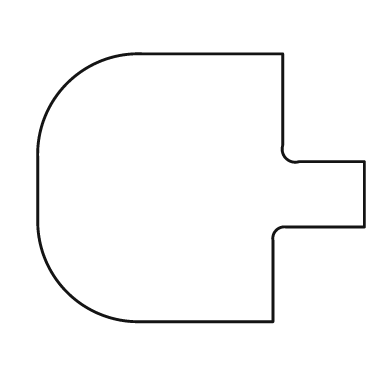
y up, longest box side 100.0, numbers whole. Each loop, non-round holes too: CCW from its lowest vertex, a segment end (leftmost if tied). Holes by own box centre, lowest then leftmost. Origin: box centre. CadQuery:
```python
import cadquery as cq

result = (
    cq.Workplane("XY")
    .moveTo(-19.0, -41.0)
    .lineTo(22.0, -41.0)
    .lineTo(22.0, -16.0)
    .threePointArc((23.0, -13.0), (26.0, -12.0))
    .lineTo(50.0, -12.0)
    .lineTo(50.0, 8.0)
    .lineTo(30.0, 8.0)
    .threePointArc((26.0, 9.0), (25.0, 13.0))
    .lineTo(25.0, 41.0)
    .lineTo(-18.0, 41.0)
    .threePointArc((-41.0, 32.0), (-50.0, 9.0))
    .lineTo(-50.0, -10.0)
    .threePointArc((-41.0, -32.0), (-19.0, -41.0))
    .close()
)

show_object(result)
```